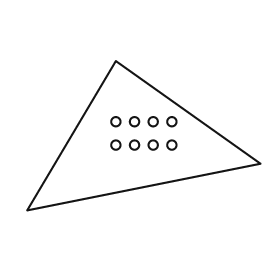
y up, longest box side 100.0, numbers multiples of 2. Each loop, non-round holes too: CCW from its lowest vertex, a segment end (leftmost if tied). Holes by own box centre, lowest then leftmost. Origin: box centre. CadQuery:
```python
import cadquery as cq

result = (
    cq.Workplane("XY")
    .moveTo(-50.0, -32.0)
    .lineTo(50.0, -12.0)
    .lineTo(-12.0, 32.0)
    .close()
    .moveTo(-12.0, -4.0)
    .circle(2.0)
    .moveTo(-4.0, -4.0)
    .circle(2.0)
    .moveTo(4.0, -4.0)
    .circle(2.0)
    .moveTo(12.0, -4.0)
    .circle(2.0)
    .moveTo(-12.0, 6.0)
    .circle(2.0)
    .moveTo(-4.0, 6.0)
    .circle(2.0)
    .moveTo(4.0, 6.0)
    .circle(2.0)
    .moveTo(12.0, 6.0)
    .circle(2.0)
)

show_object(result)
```